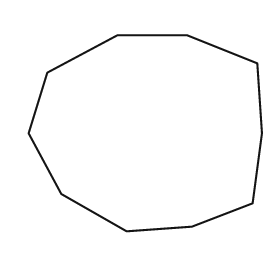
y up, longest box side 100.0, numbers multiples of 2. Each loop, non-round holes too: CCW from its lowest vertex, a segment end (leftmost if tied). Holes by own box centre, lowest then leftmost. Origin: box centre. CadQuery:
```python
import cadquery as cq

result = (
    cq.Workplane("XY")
    .moveTo(-8.0, -42.0)
    .lineTo(20.0, -40.0)
    .lineTo(46.0, -30.0)
    .lineTo(50.0, 0.0)
    .lineTo(48.0, 30.0)
    .lineTo(18.0, 42.0)
    .lineTo(-12.0, 42.0)
    .lineTo(-42.0, 26.0)
    .lineTo(-50.0, 0.0)
    .lineTo(-36.0, -26.0)
    .close()
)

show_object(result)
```